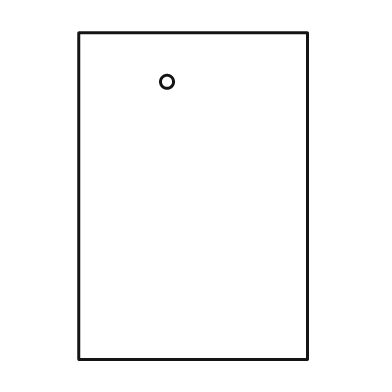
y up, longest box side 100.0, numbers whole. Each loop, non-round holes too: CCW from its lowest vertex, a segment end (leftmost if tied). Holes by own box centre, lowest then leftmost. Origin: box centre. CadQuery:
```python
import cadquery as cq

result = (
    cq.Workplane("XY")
    .moveTo(-35.0, -50.0)
    .lineTo(35.0, -50.0)
    .lineTo(35.0, 50.0)
    .lineTo(-35.0, 50.0)
    .close()
    .moveTo(-8.0, 35.0)
    .circle(2.0)
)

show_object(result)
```